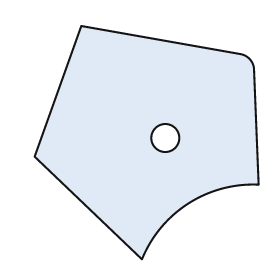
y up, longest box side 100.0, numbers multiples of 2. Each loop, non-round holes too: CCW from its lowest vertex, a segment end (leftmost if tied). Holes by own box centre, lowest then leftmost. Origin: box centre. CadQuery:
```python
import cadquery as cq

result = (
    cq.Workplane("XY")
    .moveTo(-2.0, -50.0)
    .threePointArc((18.0, -26.0), (48.0, -18.0))
    .lineTo(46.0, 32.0)
    .threePointArc((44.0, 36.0), (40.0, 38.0))
    .lineTo(-28.0, 50.0)
    .lineTo(-48.0, -6.0)
    .close()
    .moveTo(8.0, 2.0)
    .circle(6.0)
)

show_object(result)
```